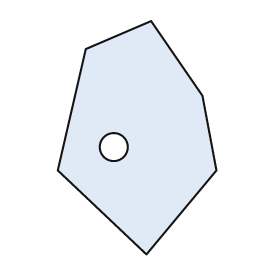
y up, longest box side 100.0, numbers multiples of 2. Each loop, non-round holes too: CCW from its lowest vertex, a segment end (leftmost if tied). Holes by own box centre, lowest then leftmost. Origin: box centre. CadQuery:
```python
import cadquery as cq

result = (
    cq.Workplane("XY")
    .moveTo(4.0, -50.0)
    .lineTo(34.0, -14.0)
    .lineTo(28.0, 18.0)
    .lineTo(6.0, 50.0)
    .lineTo(-22.0, 38.0)
    .lineTo(-34.0, -14.0)
    .close()
    .moveTo(-10.0, -4.0)
    .circle(6.0)
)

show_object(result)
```